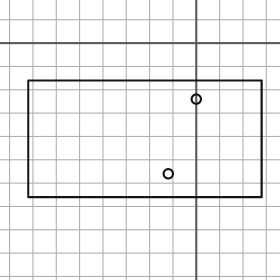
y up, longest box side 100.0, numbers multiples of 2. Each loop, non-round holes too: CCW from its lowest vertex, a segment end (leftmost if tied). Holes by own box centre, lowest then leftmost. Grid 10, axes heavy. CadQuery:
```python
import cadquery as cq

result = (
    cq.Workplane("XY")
    .moveTo(-72.0, -66.0)
    .lineTo(28.0, -66.0)
    .lineTo(28.0, -16.0)
    .lineTo(-72.0, -16.0)
    .close()
    .moveTo(-12.0, -56.0)
    .circle(2.0)
    .moveTo(0.0, -24.0)
    .circle(2.0)
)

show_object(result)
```